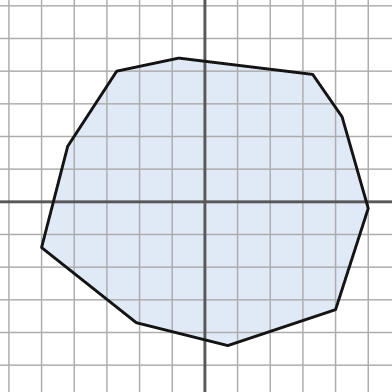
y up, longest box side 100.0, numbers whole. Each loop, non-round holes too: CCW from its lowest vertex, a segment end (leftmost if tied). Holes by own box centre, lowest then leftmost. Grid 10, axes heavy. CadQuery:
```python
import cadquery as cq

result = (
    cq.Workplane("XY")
    .moveTo(7.0, -44.0)
    .lineTo(40.0, -33.0)
    .lineTo(50.0, -2.0)
    .lineTo(42.0, 26.0)
    .lineTo(33.0, 39.0)
    .lineTo(-8.0, 44.0)
    .lineTo(-27.0, 40.0)
    .lineTo(-42.0, 17.0)
    .lineTo(-50.0, -14.0)
    .lineTo(-21.0, -37.0)
    .close()
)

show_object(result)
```